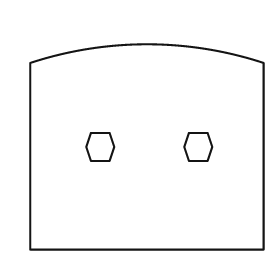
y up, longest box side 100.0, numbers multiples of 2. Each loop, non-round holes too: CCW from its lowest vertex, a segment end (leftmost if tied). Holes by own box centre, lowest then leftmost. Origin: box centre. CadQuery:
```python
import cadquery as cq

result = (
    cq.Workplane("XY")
    .moveTo(-50.0, -44.0)
    .lineTo(50.0, -44.0)
    .lineTo(50.0, 36.0)
    .threePointArc((0.0, 44.0), (-50.0, 36.0))
    .close()
    .moveTo(-24.0, -6.0)
    .lineTo(-16.0, -6.0)
    .lineTo(-14.0, 0.0)
    .lineTo(-16.0, 6.0)
    .lineTo(-24.0, 6.0)
    .lineTo(-26.0, 0.0)
    .close()
    .moveTo(18.0, -6.0)
    .lineTo(26.0, -6.0)
    .lineTo(28.0, 0.0)
    .lineTo(26.0, 6.0)
    .lineTo(18.0, 6.0)
    .lineTo(16.0, 0.0)
    .close()
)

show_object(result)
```